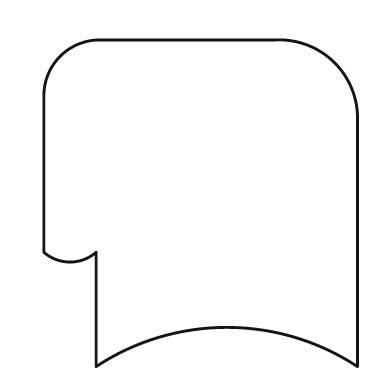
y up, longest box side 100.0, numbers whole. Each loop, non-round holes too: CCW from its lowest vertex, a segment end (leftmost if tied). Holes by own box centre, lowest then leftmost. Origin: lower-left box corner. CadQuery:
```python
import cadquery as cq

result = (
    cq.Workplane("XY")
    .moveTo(16.0, 0.0)
    .threePointArc((56.0, 12.0), (96.0, 0.0))
    .lineTo(96.0, 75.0)
    .threePointArc((89.0, 93.0), (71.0, 100.0))
    .lineTo(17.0, 100.0)
    .threePointArc((5.0, 95.0), (0.0, 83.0))
    .lineTo(0.0, 35.0)
    .threePointArc((8.0, 32.0), (16.0, 35.0))
    .close()
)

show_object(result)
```